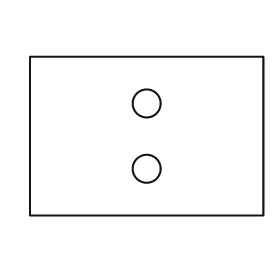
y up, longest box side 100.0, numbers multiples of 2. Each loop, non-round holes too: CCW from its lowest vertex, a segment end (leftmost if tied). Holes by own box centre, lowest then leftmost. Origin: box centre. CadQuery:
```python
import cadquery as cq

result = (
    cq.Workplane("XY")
    .moveTo(-50.0, -34.0)
    .lineTo(50.0, -34.0)
    .lineTo(50.0, 34.0)
    .lineTo(-50.0, 34.0)
    .close()
    .moveTo(0.0, -14.0)
    .circle(6.0)
    .moveTo(0.0, 14.0)
    .circle(6.0)
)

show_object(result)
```